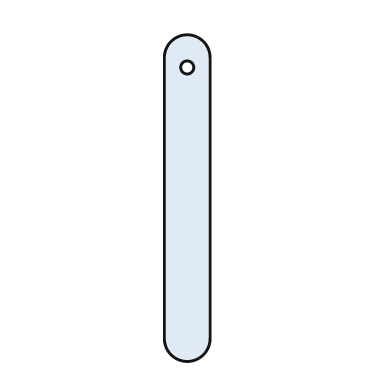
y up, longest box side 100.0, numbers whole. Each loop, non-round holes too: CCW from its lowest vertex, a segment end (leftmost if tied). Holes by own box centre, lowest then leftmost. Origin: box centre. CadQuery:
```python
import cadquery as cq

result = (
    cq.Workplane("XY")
    .moveTo(-7.0, -43.0)
    .threePointArc((0.0, -50.0), (7.0, -43.0))
    .lineTo(7.0, 43.0)
    .threePointArc((0.0, 50.0), (-7.0, 43.0))
    .close()
    .moveTo(0.0, 40.0)
    .circle(2.0)
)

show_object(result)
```